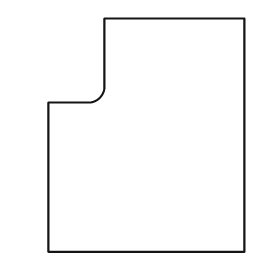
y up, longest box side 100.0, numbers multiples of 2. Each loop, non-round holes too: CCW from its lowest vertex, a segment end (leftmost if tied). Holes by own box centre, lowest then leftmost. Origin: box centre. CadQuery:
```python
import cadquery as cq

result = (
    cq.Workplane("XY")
    .moveTo(-42.0, -50.0)
    .lineTo(42.0, -50.0)
    .lineTo(42.0, 50.0)
    .lineTo(-18.0, 50.0)
    .lineTo(-18.0, 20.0)
    .threePointArc((-20.0, 16.0), (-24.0, 14.0))
    .lineTo(-42.0, 14.0)
    .close()
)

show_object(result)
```